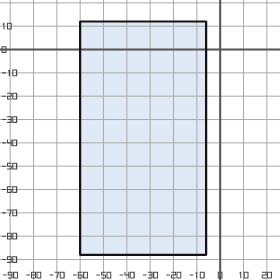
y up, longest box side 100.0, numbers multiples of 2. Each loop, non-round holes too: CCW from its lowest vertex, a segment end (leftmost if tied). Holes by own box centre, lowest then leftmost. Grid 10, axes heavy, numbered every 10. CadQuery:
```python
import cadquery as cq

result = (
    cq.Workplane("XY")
    .moveTo(-60.0, -88.0)
    .lineTo(-6.0, -88.0)
    .lineTo(-6.0, 12.0)
    .lineTo(-60.0, 12.0)
    .close()
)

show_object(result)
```